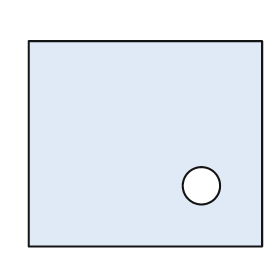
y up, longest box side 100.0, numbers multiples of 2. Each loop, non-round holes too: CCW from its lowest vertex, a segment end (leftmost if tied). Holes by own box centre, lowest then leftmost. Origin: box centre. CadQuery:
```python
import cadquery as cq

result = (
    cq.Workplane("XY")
    .moveTo(-50.0, -44.0)
    .lineTo(50.0, -44.0)
    .lineTo(50.0, 44.0)
    .lineTo(-50.0, 44.0)
    .close()
    .moveTo(24.0, -18.0)
    .circle(8.0)
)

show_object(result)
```